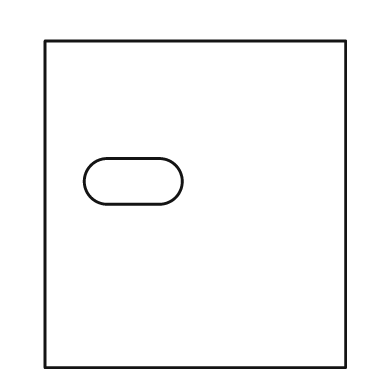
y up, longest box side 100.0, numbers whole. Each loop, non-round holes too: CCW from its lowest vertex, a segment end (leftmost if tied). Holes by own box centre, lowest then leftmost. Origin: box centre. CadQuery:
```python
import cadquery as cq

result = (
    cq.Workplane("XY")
    .moveTo(-46.0, -50.0)
    .lineTo(46.0, -50.0)
    .lineTo(46.0, 50.0)
    .lineTo(-46.0, 50.0)
    .close()
    .moveTo(-27.0, 0.0)
    .lineTo(-11.0, 0.0)
    .threePointArc((-4.0, 7.0), (-11.0, 14.0))
    .lineTo(-27.0, 14.0)
    .threePointArc((-34.0, 7.0), (-27.0, 0.0))
    .close()
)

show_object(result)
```